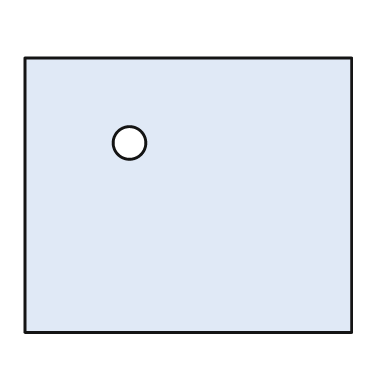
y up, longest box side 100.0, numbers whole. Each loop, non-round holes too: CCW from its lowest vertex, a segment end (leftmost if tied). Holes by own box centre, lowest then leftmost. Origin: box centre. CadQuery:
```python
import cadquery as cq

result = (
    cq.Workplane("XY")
    .moveTo(-50.0, -42.0)
    .lineTo(50.0, -42.0)
    .lineTo(50.0, 42.0)
    .lineTo(-50.0, 42.0)
    .close()
    .moveTo(-18.0, 16.0)
    .circle(5.0)
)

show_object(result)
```